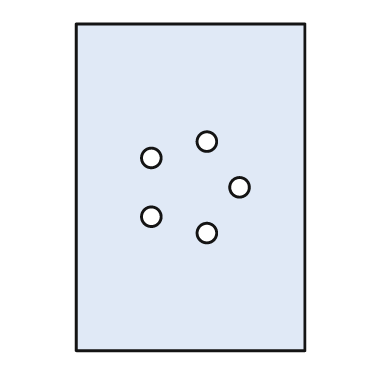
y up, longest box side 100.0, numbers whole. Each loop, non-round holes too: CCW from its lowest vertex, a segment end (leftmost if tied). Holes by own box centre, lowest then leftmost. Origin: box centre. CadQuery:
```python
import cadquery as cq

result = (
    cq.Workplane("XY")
    .moveTo(-35.0, -50.0)
    .lineTo(35.0, -50.0)
    .lineTo(35.0, 50.0)
    .lineTo(-35.0, 50.0)
    .close()
    .moveTo(5.0, -14.0)
    .circle(3.0)
    .moveTo(-12.0, -9.0)
    .circle(3.0)
    .moveTo(15.0, 0.0)
    .circle(3.0)
    .moveTo(-12.0, 9.0)
    .circle(3.0)
    .moveTo(5.0, 14.0)
    .circle(3.0)
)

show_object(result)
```